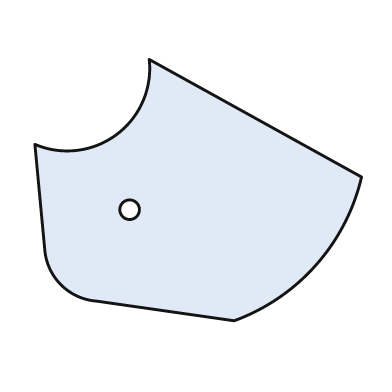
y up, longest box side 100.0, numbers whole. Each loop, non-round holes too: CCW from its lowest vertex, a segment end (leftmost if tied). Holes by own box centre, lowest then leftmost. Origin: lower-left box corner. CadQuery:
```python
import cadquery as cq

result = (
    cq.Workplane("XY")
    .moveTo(61.0, 0.0)
    .threePointArc((86.0, 17.0), (100.0, 44.0))
    .lineTo(35.0, 80.0)
    .threePointArc((25.0, 57.0), (0.0, 54.0))
    .lineTo(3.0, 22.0)
    .threePointArc((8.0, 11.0), (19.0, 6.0))
    .close()
    .moveTo(29.0, 34.0)
    .circle(3.0)
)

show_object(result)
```